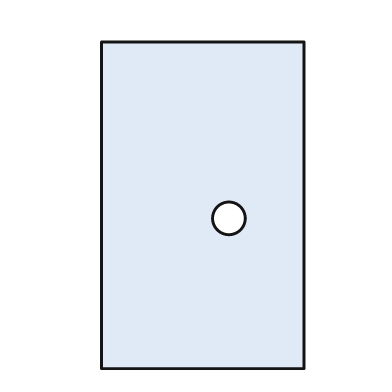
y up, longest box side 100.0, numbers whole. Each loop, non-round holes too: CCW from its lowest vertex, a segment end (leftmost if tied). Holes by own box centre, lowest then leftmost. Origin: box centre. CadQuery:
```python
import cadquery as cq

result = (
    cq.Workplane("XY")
    .moveTo(-31.0, -50.0)
    .lineTo(31.0, -50.0)
    .lineTo(31.0, 50.0)
    .lineTo(-31.0, 50.0)
    .close()
    .moveTo(8.0, -4.0)
    .circle(5.0)
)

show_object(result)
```